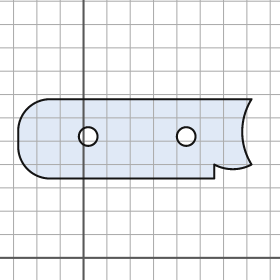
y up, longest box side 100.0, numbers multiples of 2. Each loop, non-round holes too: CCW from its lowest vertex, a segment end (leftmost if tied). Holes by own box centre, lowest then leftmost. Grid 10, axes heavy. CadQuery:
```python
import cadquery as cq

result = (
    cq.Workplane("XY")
    .moveTo(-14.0, 34.0)
    .lineTo(56.0, 34.0)
    .lineTo(56.0, 40.0)
    .threePointArc((64.0, 38.0), (72.0, 40.0))
    .threePointArc((68.0, 54.0), (72.0, 68.0))
    .lineTo(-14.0, 68.0)
    .threePointArc((-24.0, 64.0), (-28.0, 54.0))
    .lineTo(-28.0, 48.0)
    .threePointArc((-24.0, 38.0), (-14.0, 34.0))
    .close()
    .moveTo(2.0, 52.0)
    .circle(4.0)
    .moveTo(44.0, 52.0)
    .circle(4.0)
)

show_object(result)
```